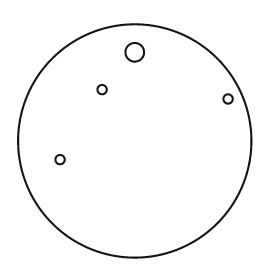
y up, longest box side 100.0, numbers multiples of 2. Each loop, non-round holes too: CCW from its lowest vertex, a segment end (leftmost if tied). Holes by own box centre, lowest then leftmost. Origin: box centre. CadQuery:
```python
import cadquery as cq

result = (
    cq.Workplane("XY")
    .moveTo(0.0, 0.0)
    .circle(50.0)
    .moveTo(-32.0, -8.0)
    .circle(2.0)
    .moveTo(40.0, 18.0)
    .circle(2.0)
    .moveTo(-14.0, 22.0)
    .circle(2.0)
    .moveTo(0.0, 38.0)
    .circle(4.0)
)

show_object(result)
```